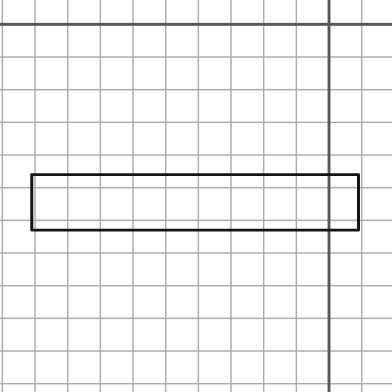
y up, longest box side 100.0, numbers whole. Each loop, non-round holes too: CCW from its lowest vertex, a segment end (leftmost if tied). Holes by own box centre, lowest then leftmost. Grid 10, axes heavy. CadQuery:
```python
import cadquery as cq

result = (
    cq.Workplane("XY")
    .moveTo(-91.0, -63.0)
    .lineTo(9.0, -63.0)
    .lineTo(9.0, -46.0)
    .lineTo(-91.0, -46.0)
    .close()
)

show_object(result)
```